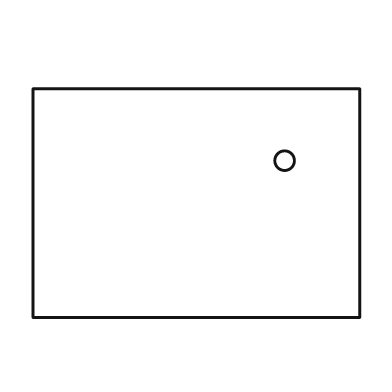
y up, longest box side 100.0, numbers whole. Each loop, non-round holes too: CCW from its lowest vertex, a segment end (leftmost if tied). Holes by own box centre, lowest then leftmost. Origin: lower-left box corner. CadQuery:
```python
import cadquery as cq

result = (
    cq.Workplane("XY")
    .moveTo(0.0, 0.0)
    .lineTo(100.0, 0.0)
    .lineTo(100.0, 70.0)
    .lineTo(0.0, 70.0)
    .close()
    .moveTo(77.0, 48.0)
    .circle(3.0)
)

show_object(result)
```